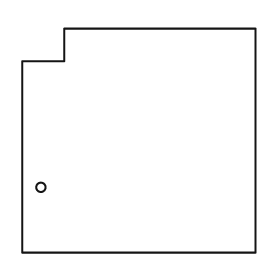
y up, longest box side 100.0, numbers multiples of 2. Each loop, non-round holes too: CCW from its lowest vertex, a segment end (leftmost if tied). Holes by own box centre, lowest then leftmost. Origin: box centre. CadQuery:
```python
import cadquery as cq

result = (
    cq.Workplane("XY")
    .moveTo(-50.0, -48.0)
    .lineTo(50.0, -48.0)
    .lineTo(50.0, 48.0)
    .lineTo(-32.0, 48.0)
    .lineTo(-32.0, 34.0)
    .lineTo(-50.0, 34.0)
    .close()
    .moveTo(-42.0, -20.0)
    .circle(2.0)
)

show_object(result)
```